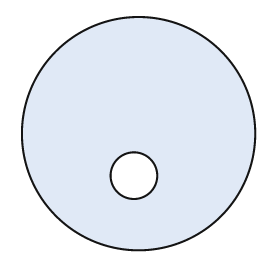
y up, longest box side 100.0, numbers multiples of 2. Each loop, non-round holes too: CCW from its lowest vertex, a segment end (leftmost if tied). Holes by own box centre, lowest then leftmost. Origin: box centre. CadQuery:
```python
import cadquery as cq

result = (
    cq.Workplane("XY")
    .moveTo(0.0, 0.0)
    .circle(50.0)
    .moveTo(-2.0, -18.0)
    .circle(10.0)
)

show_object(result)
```